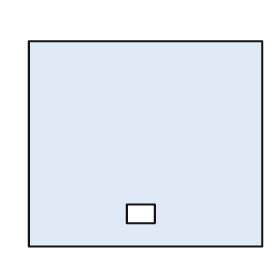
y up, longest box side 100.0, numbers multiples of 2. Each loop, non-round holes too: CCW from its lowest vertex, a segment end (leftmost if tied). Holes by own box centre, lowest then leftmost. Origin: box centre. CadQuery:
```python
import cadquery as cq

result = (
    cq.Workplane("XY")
    .moveTo(-50.0, -44.0)
    .lineTo(50.0, -44.0)
    .lineTo(50.0, 44.0)
    .lineTo(-50.0, 44.0)
    .close()
    .moveTo(-8.0, -34.0)
    .lineTo(4.0, -34.0)
    .lineTo(4.0, -26.0)
    .lineTo(-8.0, -26.0)
    .close()
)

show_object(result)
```